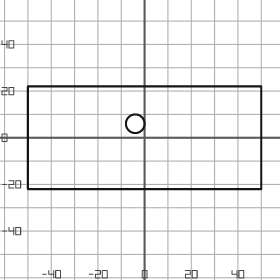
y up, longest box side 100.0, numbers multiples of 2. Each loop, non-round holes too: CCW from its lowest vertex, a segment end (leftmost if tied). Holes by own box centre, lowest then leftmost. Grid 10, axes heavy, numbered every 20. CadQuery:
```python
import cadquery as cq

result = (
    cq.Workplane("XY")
    .moveTo(-50.0, -22.0)
    .lineTo(50.0, -22.0)
    .lineTo(50.0, 22.0)
    .lineTo(-50.0, 22.0)
    .close()
    .moveTo(-4.0, 6.0)
    .circle(4.0)
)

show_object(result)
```